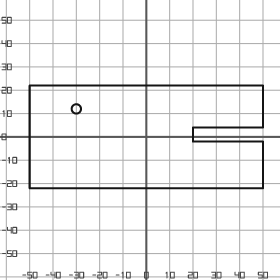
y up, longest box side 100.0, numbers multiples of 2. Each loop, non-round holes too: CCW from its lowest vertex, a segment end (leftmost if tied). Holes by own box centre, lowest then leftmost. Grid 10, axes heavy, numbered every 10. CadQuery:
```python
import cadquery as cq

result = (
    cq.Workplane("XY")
    .moveTo(-50.0, -22.0)
    .lineTo(50.0, -22.0)
    .lineTo(50.0, -2.0)
    .lineTo(20.0, -2.0)
    .lineTo(20.0, 4.0)
    .lineTo(50.0, 4.0)
    .lineTo(50.0, 22.0)
    .lineTo(-50.0, 22.0)
    .close()
    .moveTo(-30.0, 12.0)
    .circle(2.0)
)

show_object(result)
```